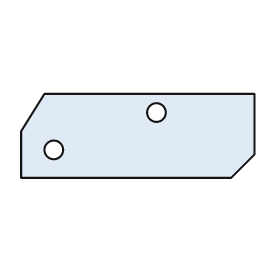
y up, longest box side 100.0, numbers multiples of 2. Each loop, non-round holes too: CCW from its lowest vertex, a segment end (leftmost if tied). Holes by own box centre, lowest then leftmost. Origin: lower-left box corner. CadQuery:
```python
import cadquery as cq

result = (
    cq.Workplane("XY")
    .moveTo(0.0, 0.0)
    .lineTo(90.0, 0.0)
    .lineTo(100.0, 10.0)
    .lineTo(100.0, 36.0)
    .lineTo(10.0, 36.0)
    .lineTo(0.0, 20.0)
    .close()
    .moveTo(14.0, 12.0)
    .circle(4.0)
    .moveTo(58.0, 28.0)
    .circle(4.0)
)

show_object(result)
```